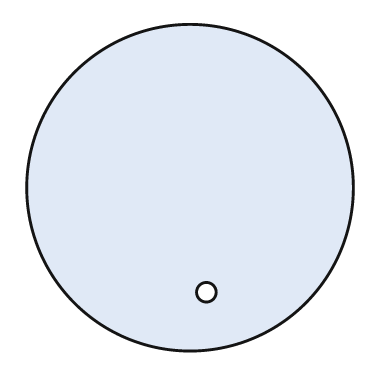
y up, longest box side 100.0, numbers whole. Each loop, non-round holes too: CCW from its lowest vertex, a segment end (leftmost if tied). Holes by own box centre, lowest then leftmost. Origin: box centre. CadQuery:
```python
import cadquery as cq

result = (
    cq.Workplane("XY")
    .moveTo(0.0, 0.0)
    .circle(50.0)
    .moveTo(5.0, -32.0)
    .circle(3.0)
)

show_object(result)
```